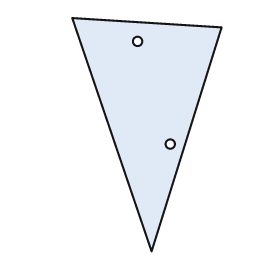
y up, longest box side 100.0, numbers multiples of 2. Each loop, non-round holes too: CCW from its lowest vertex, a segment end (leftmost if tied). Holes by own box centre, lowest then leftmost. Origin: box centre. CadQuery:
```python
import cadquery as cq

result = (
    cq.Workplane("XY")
    .moveTo(2.0, -50.0)
    .lineTo(32.0, 46.0)
    .lineTo(-32.0, 50.0)
    .close()
    .moveTo(10.0, -4.0)
    .circle(2.0)
    .moveTo(-4.0, 40.0)
    .circle(2.0)
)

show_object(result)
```